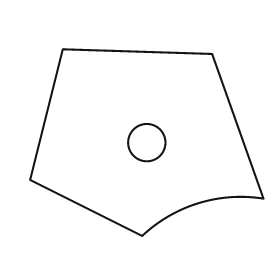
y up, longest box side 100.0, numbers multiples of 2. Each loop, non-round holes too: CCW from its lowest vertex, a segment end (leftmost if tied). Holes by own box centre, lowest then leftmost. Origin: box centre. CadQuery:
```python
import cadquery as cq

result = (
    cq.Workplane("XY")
    .moveTo(-2.0, -40.0)
    .threePointArc((22.0, -26.0), (50.0, -24.0))
    .lineTo(28.0, 38.0)
    .lineTo(-36.0, 40.0)
    .lineTo(-50.0, -16.0)
    .close()
    .moveTo(0.0, 0.0)
    .circle(8.0)
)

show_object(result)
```